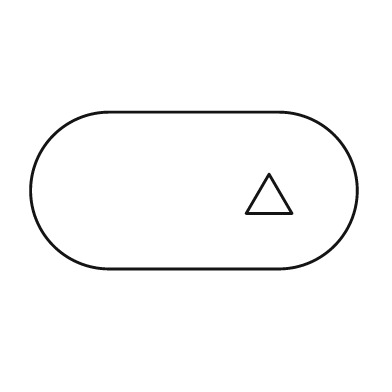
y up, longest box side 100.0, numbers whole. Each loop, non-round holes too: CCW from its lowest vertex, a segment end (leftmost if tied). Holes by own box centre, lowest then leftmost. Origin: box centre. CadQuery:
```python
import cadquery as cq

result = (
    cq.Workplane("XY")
    .moveTo(-26.0, -24.0)
    .lineTo(26.0, -24.0)
    .threePointArc((50.0, 0.0), (26.0, 24.0))
    .lineTo(-26.0, 24.0)
    .threePointArc((-50.0, 0.0), (-26.0, -24.0))
    .close()
    .moveTo(16.0, -7.0)
    .lineTo(30.0, -7.0)
    .lineTo(23.0, 5.0)
    .close()
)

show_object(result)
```